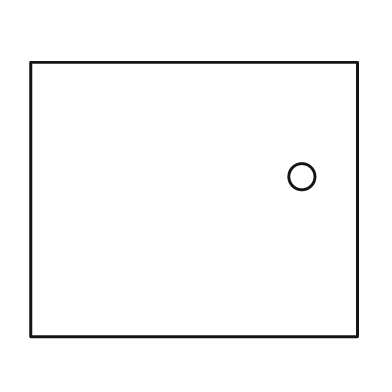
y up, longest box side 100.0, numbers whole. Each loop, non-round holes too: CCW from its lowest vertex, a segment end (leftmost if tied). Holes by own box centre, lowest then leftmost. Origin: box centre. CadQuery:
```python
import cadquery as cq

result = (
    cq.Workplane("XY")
    .moveTo(-50.0, -42.0)
    .lineTo(50.0, -42.0)
    .lineTo(50.0, 42.0)
    .lineTo(-50.0, 42.0)
    .close()
    .moveTo(33.0, 7.0)
    .circle(4.0)
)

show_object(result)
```